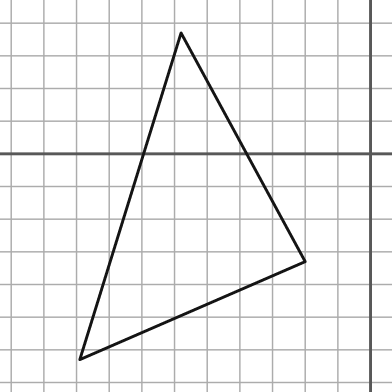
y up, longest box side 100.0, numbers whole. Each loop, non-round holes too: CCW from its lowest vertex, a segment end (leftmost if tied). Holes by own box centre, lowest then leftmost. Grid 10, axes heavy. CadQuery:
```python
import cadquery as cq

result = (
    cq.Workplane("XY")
    .moveTo(-89.0, -63.0)
    .lineTo(-20.0, -33.0)
    .lineTo(-58.0, 37.0)
    .close()
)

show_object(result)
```